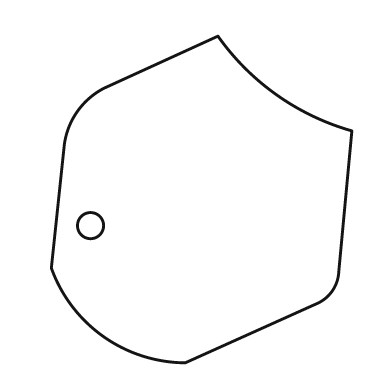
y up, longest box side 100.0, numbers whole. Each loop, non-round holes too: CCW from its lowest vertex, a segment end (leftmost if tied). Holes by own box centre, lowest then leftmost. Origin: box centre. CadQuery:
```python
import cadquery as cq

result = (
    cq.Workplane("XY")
    .moveTo(-5.0, -50.0)
    .lineTo(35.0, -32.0)
    .threePointArc((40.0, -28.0), (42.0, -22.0))
    .lineTo(46.0, 21.0)
    .threePointArc((23.0, 32.0), (5.0, 50.0))
    .lineTo(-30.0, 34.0)
    .threePointArc((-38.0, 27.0), (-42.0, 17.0))
    .lineTo(-46.0, -21.0)
    .threePointArc((-30.0, -42.0), (-5.0, -50.0))
    .close()
    .moveTo(-34.0, -8.0)
    .circle(4.0)
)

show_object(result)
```